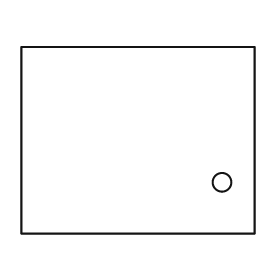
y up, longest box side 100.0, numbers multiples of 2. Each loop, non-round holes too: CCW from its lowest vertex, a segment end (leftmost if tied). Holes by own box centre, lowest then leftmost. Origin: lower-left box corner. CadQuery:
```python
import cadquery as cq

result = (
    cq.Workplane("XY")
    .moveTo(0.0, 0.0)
    .lineTo(100.0, 0.0)
    .lineTo(100.0, 80.0)
    .lineTo(0.0, 80.0)
    .close()
    .moveTo(86.0, 22.0)
    .circle(4.0)
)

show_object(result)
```